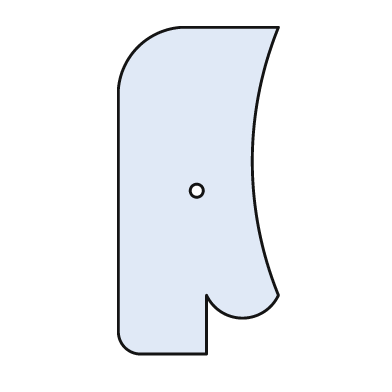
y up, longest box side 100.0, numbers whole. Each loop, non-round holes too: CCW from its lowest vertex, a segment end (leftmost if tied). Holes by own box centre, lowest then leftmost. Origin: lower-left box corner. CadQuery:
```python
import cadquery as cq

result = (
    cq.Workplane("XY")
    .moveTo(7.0, 0.0)
    .lineTo(27.0, 0.0)
    .lineTo(27.0, 18.0)
    .threePointArc((38.0, 11.0), (49.0, 18.0))
    .threePointArc((41.0, 59.0), (49.0, 100.0))
    .lineTo(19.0, 100.0)
    .threePointArc((6.0, 94.0), (0.0, 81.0))
    .lineTo(0.0, 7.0)
    .threePointArc((2.0, 2.0), (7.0, 0.0))
    .close()
    .moveTo(24.0, 50.0)
    .circle(2.0)
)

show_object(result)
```